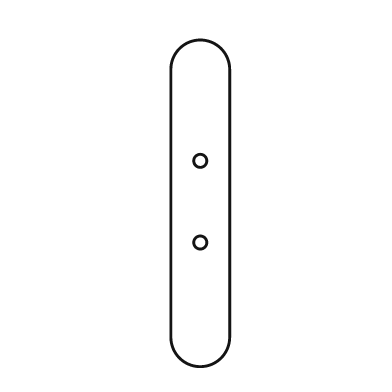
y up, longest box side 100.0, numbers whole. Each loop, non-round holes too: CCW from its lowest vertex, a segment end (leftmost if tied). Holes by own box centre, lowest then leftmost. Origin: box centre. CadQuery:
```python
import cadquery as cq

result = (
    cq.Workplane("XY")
    .moveTo(-9.0, -41.0)
    .threePointArc((0.0, -50.0), (9.0, -41.0))
    .lineTo(9.0, 41.0)
    .threePointArc((0.0, 50.0), (-9.0, 41.0))
    .close()
    .moveTo(0.0, -12.0)
    .circle(2.0)
    .moveTo(0.0, 13.0)
    .circle(2.0)
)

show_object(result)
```